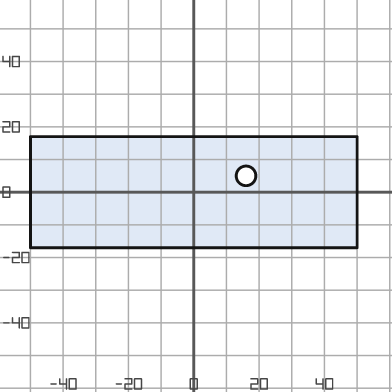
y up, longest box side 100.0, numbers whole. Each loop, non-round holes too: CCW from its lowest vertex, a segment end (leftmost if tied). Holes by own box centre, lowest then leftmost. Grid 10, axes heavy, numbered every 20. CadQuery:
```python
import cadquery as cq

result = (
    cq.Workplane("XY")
    .moveTo(-50.0, -17.0)
    .lineTo(50.0, -17.0)
    .lineTo(50.0, 17.0)
    .lineTo(-50.0, 17.0)
    .close()
    .moveTo(16.0, 5.0)
    .circle(3.0)
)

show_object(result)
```